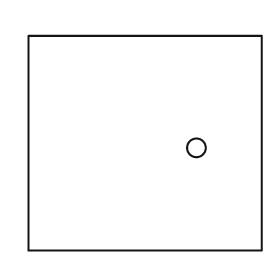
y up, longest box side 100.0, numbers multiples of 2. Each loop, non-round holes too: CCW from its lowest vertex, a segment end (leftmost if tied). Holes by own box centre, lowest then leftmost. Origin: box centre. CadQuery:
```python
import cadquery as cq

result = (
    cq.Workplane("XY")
    .moveTo(-50.0, -46.0)
    .lineTo(50.0, -46.0)
    .lineTo(50.0, 46.0)
    .lineTo(-50.0, 46.0)
    .close()
    .moveTo(22.0, -2.0)
    .circle(4.0)
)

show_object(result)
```